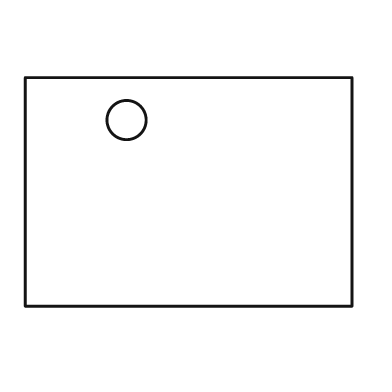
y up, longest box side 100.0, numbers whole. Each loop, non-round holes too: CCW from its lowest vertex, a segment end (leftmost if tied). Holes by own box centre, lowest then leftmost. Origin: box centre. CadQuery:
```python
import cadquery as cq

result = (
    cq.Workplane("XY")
    .moveTo(-50.0, -35.0)
    .lineTo(50.0, -35.0)
    .lineTo(50.0, 35.0)
    .lineTo(-50.0, 35.0)
    .close()
    .moveTo(-19.0, 22.0)
    .circle(6.0)
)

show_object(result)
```